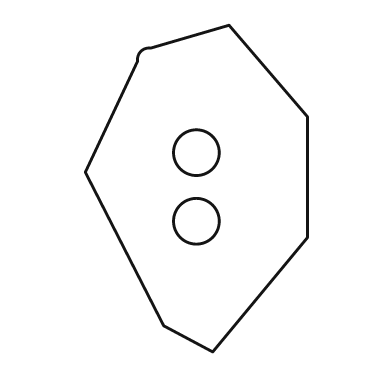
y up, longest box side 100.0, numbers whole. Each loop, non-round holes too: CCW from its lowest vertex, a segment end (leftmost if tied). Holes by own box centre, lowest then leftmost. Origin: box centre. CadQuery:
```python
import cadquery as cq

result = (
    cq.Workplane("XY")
    .moveTo(5.0, -50.0)
    .lineTo(34.0, -15.0)
    .lineTo(34.0, 22.0)
    .lineTo(10.0, 50.0)
    .lineTo(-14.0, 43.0)
    .threePointArc((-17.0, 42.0), (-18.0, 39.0))
    .lineTo(-34.0, 5.0)
    .lineTo(-10.0, -42.0)
    .close()
    .moveTo(0.0, -10.0)
    .circle(7.0)
    .moveTo(0.0, 11.0)
    .circle(7.0)
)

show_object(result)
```